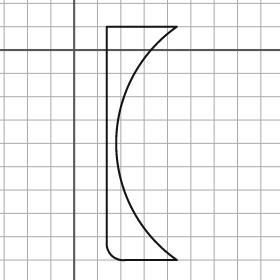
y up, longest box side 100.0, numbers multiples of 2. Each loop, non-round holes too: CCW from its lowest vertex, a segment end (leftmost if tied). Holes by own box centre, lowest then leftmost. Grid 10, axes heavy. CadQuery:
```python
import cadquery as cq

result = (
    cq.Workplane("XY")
    .moveTo(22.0, -90.0)
    .lineTo(44.0, -90.0)
    .threePointArc((18.0, -40.0), (44.0, 10.0))
    .lineTo(14.0, 10.0)
    .lineTo(14.0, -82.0)
    .threePointArc((16.0, -88.0), (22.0, -90.0))
    .close()
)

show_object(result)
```